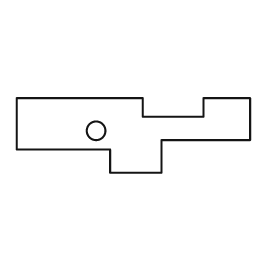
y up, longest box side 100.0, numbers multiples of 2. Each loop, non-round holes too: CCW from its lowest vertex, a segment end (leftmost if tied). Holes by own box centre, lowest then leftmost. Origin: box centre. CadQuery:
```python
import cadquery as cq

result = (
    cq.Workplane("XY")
    .moveTo(-10.0, -16.0)
    .lineTo(12.0, -16.0)
    .lineTo(12.0, -2.0)
    .lineTo(50.0, -2.0)
    .lineTo(50.0, 16.0)
    .lineTo(30.0, 16.0)
    .lineTo(30.0, 8.0)
    .lineTo(4.0, 8.0)
    .lineTo(4.0, 16.0)
    .lineTo(-50.0, 16.0)
    .lineTo(-50.0, -6.0)
    .lineTo(-10.0, -6.0)
    .close()
    .moveTo(-16.0, 2.0)
    .circle(4.0)
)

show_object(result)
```